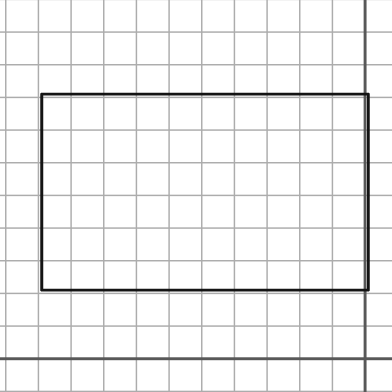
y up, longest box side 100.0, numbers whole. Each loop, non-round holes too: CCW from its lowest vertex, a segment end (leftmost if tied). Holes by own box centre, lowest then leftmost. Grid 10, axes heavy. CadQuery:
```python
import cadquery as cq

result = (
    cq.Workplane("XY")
    .moveTo(-99.0, 21.0)
    .lineTo(1.0, 21.0)
    .lineTo(1.0, 81.0)
    .lineTo(-99.0, 81.0)
    .close()
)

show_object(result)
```